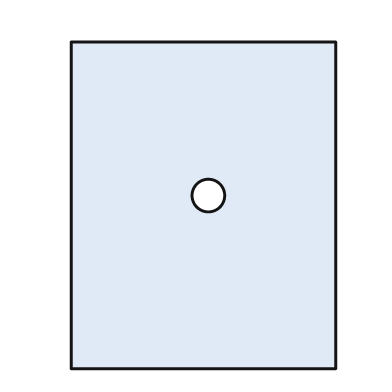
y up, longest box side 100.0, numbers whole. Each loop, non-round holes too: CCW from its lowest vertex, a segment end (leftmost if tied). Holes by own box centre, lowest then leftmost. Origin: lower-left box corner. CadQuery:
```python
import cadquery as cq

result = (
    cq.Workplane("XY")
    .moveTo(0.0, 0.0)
    .lineTo(81.0, 0.0)
    .lineTo(81.0, 100.0)
    .lineTo(0.0, 100.0)
    .close()
    .moveTo(42.0, 53.0)
    .circle(5.0)
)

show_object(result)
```